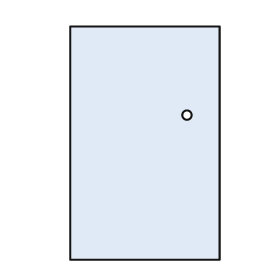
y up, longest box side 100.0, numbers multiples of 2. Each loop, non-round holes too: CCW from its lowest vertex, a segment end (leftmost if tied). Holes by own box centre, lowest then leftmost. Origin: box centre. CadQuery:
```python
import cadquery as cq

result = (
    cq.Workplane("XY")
    .moveTo(-32.0, -50.0)
    .lineTo(32.0, -50.0)
    .lineTo(32.0, 50.0)
    .lineTo(-32.0, 50.0)
    .close()
    .moveTo(18.0, 12.0)
    .circle(2.0)
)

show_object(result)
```